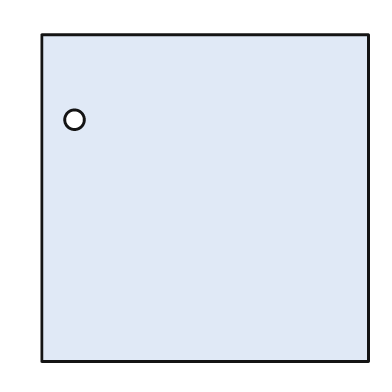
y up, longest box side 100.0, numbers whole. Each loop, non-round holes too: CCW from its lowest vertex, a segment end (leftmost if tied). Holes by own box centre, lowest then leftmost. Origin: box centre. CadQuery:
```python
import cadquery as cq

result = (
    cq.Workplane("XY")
    .moveTo(-50.0, -50.0)
    .lineTo(50.0, -50.0)
    .lineTo(50.0, 50.0)
    .lineTo(-50.0, 50.0)
    .close()
    .moveTo(-40.0, 24.0)
    .circle(3.0)
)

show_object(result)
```